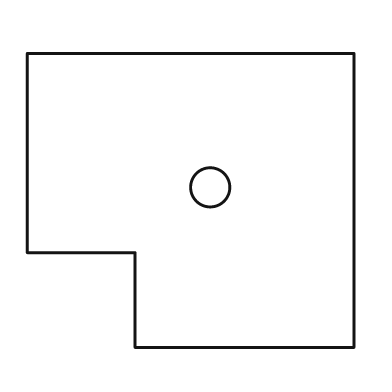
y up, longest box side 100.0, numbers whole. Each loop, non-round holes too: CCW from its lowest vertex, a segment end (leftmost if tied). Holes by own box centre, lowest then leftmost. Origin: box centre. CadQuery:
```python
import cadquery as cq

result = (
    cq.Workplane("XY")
    .moveTo(-17.0, -45.0)
    .lineTo(50.0, -45.0)
    .lineTo(50.0, 45.0)
    .lineTo(-50.0, 45.0)
    .lineTo(-50.0, -16.0)
    .lineTo(-17.0, -16.0)
    .close()
    .moveTo(6.0, 4.0)
    .circle(6.0)
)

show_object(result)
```